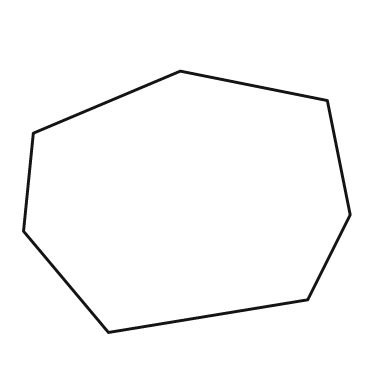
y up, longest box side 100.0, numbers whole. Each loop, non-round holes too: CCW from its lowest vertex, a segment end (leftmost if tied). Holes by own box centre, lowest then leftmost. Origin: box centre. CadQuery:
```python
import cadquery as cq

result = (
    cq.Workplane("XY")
    .moveTo(-24.0, -40.0)
    .lineTo(37.0, -30.0)
    .lineTo(50.0, -4.0)
    .lineTo(43.0, 31.0)
    .lineTo(-2.0, 40.0)
    .lineTo(-47.0, 21.0)
    .lineTo(-50.0, -9.0)
    .close()
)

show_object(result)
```